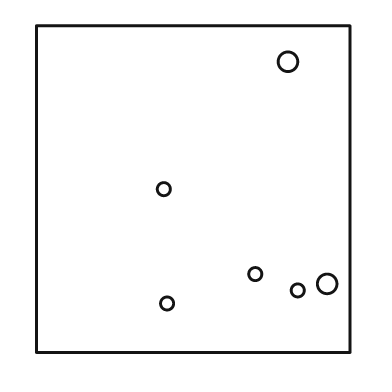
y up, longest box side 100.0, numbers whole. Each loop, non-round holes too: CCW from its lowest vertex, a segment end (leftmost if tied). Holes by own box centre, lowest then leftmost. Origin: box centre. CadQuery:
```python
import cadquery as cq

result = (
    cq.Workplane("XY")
    .moveTo(-48.0, -50.0)
    .lineTo(48.0, -50.0)
    .lineTo(48.0, 50.0)
    .lineTo(-48.0, 50.0)
    .close()
    .moveTo(-8.0, -35.0)
    .circle(2.0)
    .moveTo(32.0, -31.0)
    .circle(2.0)
    .moveTo(41.0, -29.0)
    .circle(3.0)
    .moveTo(19.0, -26.0)
    .circle(2.0)
    .moveTo(-9.0, 0.0)
    .circle(2.0)
    .moveTo(29.0, 39.0)
    .circle(3.0)
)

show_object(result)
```